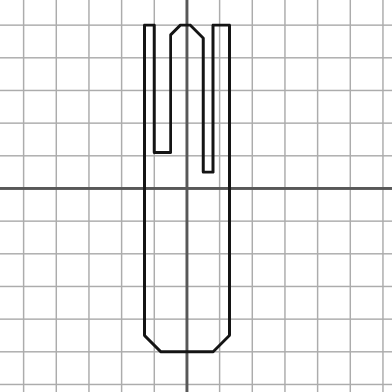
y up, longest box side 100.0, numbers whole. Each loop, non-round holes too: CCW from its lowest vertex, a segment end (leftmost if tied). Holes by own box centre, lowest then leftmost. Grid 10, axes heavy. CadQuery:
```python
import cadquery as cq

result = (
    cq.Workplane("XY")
    .moveTo(-8.0, -50.0)
    .lineTo(8.0, -50.0)
    .lineTo(13.0, -45.0)
    .lineTo(13.0, 50.0)
    .lineTo(8.0, 50.0)
    .lineTo(8.0, 5.0)
    .lineTo(5.0, 5.0)
    .lineTo(5.0, 46.0)
    .lineTo(1.0, 50.0)
    .lineTo(-2.0, 50.0)
    .lineTo(-5.0, 47.0)
    .lineTo(-5.0, 11.0)
    .lineTo(-10.0, 11.0)
    .lineTo(-10.0, 50.0)
    .lineTo(-13.0, 50.0)
    .lineTo(-13.0, -45.0)
    .close()
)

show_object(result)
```